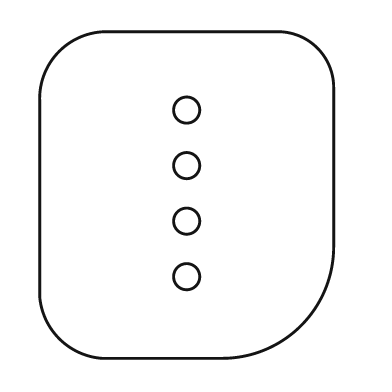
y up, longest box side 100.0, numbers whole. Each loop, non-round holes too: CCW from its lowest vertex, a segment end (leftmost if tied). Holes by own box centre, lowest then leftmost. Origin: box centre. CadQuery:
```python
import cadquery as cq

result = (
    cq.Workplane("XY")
    .moveTo(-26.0, -50.0)
    .lineTo(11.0, -50.0)
    .threePointArc((35.0, -40.0), (45.0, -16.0))
    .lineTo(45.0, 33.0)
    .threePointArc((40.0, 45.0), (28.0, 50.0))
    .lineTo(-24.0, 50.0)
    .threePointArc((-39.0, 44.0), (-45.0, 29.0))
    .lineTo(-45.0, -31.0)
    .threePointArc((-39.0, -44.0), (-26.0, -50.0))
    .close()
    .moveTo(0.0, -25.0)
    .circle(4.0)
    .moveTo(0.0, -8.0)
    .circle(4.0)
    .moveTo(0.0, 9.0)
    .circle(4.0)
    .moveTo(0.0, 26.0)
    .circle(4.0)
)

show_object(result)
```